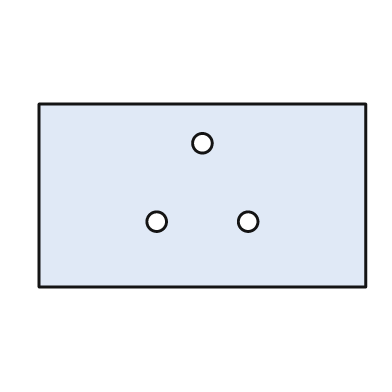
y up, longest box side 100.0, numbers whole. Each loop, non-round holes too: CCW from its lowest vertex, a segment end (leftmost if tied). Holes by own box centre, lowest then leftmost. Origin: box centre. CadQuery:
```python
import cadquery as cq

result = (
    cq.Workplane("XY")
    .moveTo(-50.0, -28.0)
    .lineTo(50.0, -28.0)
    .lineTo(50.0, 28.0)
    .lineTo(-50.0, 28.0)
    .close()
    .moveTo(-14.0, -8.0)
    .circle(3.0)
    .moveTo(14.0, -8.0)
    .circle(3.0)
    .moveTo(0.0, 16.0)
    .circle(3.0)
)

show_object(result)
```